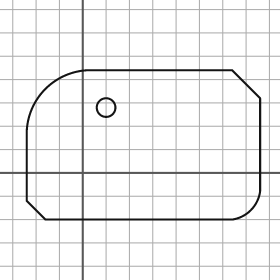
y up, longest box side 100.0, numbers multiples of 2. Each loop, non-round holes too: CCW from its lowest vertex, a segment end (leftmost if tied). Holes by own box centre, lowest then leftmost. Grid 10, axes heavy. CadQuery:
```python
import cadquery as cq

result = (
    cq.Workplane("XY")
    .moveTo(-16.0, -20.0)
    .lineTo(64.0, -20.0)
    .threePointArc((72.0, -16.0), (76.0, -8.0))
    .lineTo(76.0, 32.0)
    .lineTo(64.0, 44.0)
    .lineTo(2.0, 44.0)
    .threePointArc((-16.0, 36.0), (-24.0, 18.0))
    .lineTo(-24.0, -12.0)
    .close()
    .moveTo(10.0, 28.0)
    .circle(4.0)
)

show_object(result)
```